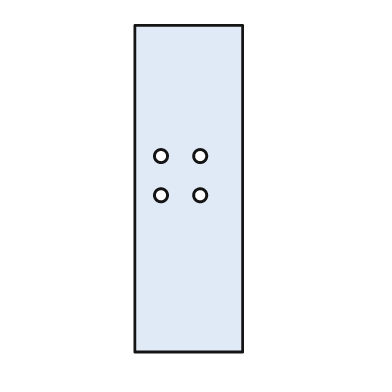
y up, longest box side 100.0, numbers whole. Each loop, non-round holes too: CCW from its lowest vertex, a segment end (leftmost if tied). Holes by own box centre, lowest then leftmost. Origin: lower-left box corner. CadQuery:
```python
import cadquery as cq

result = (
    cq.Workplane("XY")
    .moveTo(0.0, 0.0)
    .lineTo(33.0, 0.0)
    .lineTo(33.0, 100.0)
    .lineTo(0.0, 100.0)
    .close()
    .moveTo(8.0, 48.0)
    .circle(2.0)
    .moveTo(20.0, 48.0)
    .circle(2.0)
    .moveTo(8.0, 60.0)
    .circle(2.0)
    .moveTo(20.0, 60.0)
    .circle(2.0)
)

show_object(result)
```